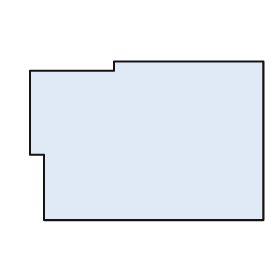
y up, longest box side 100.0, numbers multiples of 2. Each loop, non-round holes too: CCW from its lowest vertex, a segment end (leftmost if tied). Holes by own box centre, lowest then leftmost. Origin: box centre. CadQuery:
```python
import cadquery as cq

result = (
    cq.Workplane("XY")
    .moveTo(-44.0, -34.0)
    .lineTo(50.0, -34.0)
    .lineTo(50.0, 34.0)
    .lineTo(-14.0, 34.0)
    .lineTo(-14.0, 30.0)
    .lineTo(-50.0, 30.0)
    .lineTo(-50.0, -6.0)
    .lineTo(-44.0, -6.0)
    .close()
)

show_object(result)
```